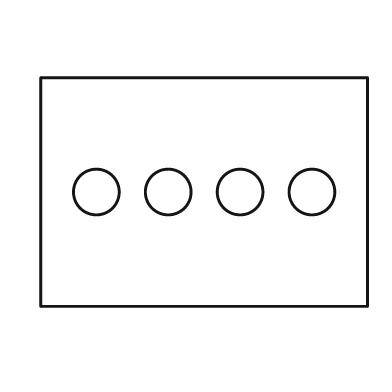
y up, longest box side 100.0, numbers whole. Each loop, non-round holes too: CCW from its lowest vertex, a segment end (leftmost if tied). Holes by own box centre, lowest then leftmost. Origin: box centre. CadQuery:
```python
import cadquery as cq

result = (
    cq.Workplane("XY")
    .moveTo(-50.0, -35.0)
    .lineTo(50.0, -35.0)
    .lineTo(50.0, 35.0)
    .lineTo(-50.0, 35.0)
    .close()
    .moveTo(-33.0, 0.0)
    .circle(7.0)
    .moveTo(-11.0, 0.0)
    .circle(7.0)
    .moveTo(11.0, 0.0)
    .circle(7.0)
    .moveTo(33.0, 0.0)
    .circle(7.0)
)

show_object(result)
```